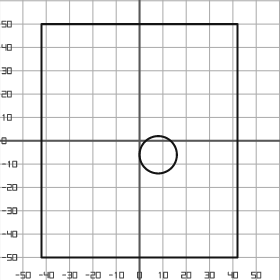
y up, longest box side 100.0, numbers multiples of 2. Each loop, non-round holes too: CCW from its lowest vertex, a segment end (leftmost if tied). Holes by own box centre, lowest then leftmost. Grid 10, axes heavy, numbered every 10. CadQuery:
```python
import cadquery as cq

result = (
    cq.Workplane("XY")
    .moveTo(-42.0, -50.0)
    .lineTo(42.0, -50.0)
    .lineTo(42.0, 50.0)
    .lineTo(-42.0, 50.0)
    .close()
    .moveTo(8.0, -6.0)
    .circle(8.0)
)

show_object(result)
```